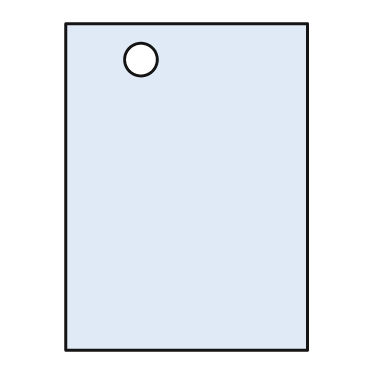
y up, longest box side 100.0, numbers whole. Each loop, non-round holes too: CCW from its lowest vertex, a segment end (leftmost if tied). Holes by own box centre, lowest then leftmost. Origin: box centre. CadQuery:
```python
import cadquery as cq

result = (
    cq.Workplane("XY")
    .moveTo(-37.0, -50.0)
    .lineTo(37.0, -50.0)
    .lineTo(37.0, 50.0)
    .lineTo(-37.0, 50.0)
    .close()
    .moveTo(-14.0, 39.0)
    .circle(5.0)
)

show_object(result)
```